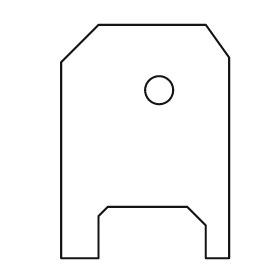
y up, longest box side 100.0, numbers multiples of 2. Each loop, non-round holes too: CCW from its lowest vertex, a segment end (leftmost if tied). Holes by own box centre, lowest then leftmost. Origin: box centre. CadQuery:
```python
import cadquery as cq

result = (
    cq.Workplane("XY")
    .moveTo(-36.0, -50.0)
    .lineTo(-20.0, -50.0)
    .lineTo(-20.0, -32.0)
    .lineTo(-16.0, -28.0)
    .lineTo(18.0, -28.0)
    .lineTo(26.0, -36.0)
    .lineTo(26.0, -50.0)
    .lineTo(36.0, -50.0)
    .lineTo(36.0, 36.0)
    .lineTo(26.0, 50.0)
    .lineTo(-20.0, 50.0)
    .lineTo(-36.0, 34.0)
    .close()
    .moveTo(6.0, 22.0)
    .circle(6.0)
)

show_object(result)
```